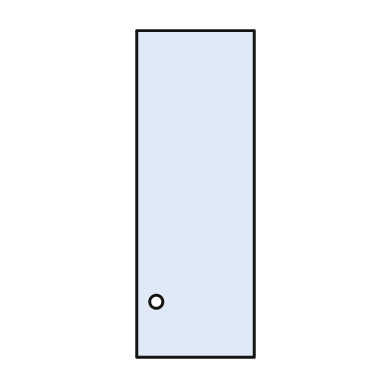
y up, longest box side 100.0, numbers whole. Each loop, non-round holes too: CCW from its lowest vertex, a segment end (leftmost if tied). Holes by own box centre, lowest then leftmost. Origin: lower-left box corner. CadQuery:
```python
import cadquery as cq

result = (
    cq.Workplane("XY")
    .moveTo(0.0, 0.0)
    .lineTo(36.0, 0.0)
    .lineTo(36.0, 100.0)
    .lineTo(0.0, 100.0)
    .close()
    .moveTo(6.0, 17.0)
    .circle(2.0)
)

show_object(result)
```